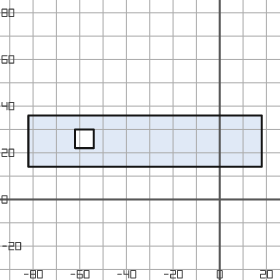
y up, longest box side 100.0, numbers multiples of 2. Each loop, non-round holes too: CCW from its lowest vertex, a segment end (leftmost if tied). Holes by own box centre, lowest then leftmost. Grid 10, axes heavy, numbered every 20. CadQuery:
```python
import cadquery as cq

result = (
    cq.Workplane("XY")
    .moveTo(-82.0, 14.0)
    .lineTo(18.0, 14.0)
    .lineTo(18.0, 36.0)
    .lineTo(-82.0, 36.0)
    .close()
    .moveTo(-62.0, 22.0)
    .lineTo(-54.0, 22.0)
    .lineTo(-54.0, 30.0)
    .lineTo(-62.0, 30.0)
    .close()
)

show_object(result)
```